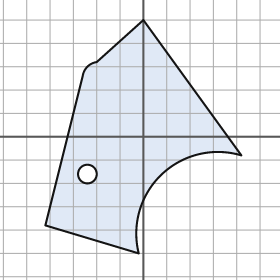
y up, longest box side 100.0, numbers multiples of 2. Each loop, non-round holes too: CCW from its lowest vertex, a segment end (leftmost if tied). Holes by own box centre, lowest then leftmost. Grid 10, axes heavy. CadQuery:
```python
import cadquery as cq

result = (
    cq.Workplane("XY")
    .moveTo(-2.0, -50.0)
    .threePointArc((8.0, -16.0), (42.0, -8.0))
    .lineTo(0.0, 50.0)
    .lineTo(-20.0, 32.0)
    .threePointArc((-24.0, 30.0), (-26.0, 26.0))
    .lineTo(-42.0, -38.0)
    .close()
    .moveTo(-24.0, -16.0)
    .circle(4.0)
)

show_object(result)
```